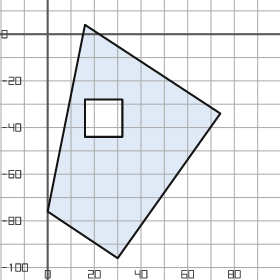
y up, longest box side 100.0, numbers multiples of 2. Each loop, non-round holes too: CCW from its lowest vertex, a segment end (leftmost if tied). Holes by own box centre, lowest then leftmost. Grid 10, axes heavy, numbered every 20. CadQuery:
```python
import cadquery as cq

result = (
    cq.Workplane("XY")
    .moveTo(30.0, -96.0)
    .lineTo(74.0, -34.0)
    .lineTo(16.0, 4.0)
    .lineTo(0.0, -76.0)
    .close()
    .moveTo(16.0, -44.0)
    .lineTo(32.0, -44.0)
    .lineTo(32.0, -28.0)
    .lineTo(16.0, -28.0)
    .close()
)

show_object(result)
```